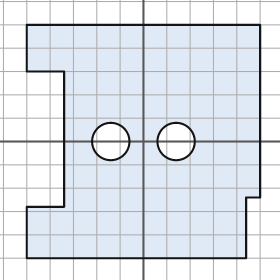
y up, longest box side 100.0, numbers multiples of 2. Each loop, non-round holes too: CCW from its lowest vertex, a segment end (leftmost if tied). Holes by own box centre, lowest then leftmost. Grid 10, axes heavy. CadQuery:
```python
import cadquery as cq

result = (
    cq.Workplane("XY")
    .moveTo(-50.0, -50.0)
    .lineTo(44.0, -50.0)
    .lineTo(44.0, -24.0)
    .lineTo(50.0, -24.0)
    .lineTo(50.0, 50.0)
    .lineTo(-50.0, 50.0)
    .lineTo(-50.0, 30.0)
    .lineTo(-34.0, 30.0)
    .lineTo(-34.0, -28.0)
    .lineTo(-50.0, -28.0)
    .close()
    .moveTo(-14.0, 0.0)
    .circle(8.0)
    .moveTo(14.0, 0.0)
    .circle(8.0)
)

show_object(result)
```